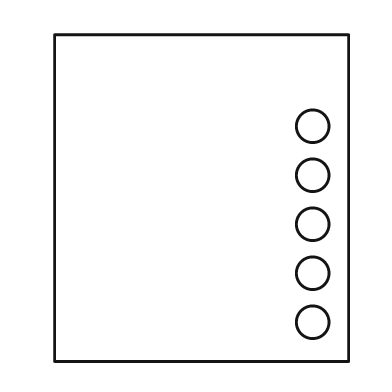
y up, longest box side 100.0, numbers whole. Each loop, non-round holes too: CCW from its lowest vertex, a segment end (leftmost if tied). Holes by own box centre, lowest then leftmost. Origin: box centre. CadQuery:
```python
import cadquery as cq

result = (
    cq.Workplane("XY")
    .moveTo(-45.0, -50.0)
    .lineTo(45.0, -50.0)
    .lineTo(45.0, 50.0)
    .lineTo(-45.0, 50.0)
    .close()
    .moveTo(34.0, -38.0)
    .circle(5.0)
    .moveTo(34.0, -23.0)
    .circle(5.0)
    .moveTo(34.0, -8.0)
    .circle(5.0)
    .moveTo(34.0, 7.0)
    .circle(5.0)
    .moveTo(34.0, 22.0)
    .circle(5.0)
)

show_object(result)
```